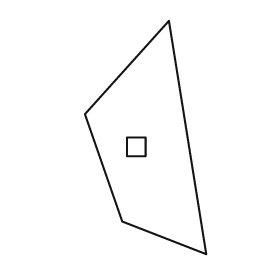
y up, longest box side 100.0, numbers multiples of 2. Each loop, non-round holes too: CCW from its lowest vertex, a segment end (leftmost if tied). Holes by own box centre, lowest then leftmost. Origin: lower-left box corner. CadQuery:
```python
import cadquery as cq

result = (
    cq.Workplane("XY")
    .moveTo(52.0, 0.0)
    .lineTo(36.0, 100.0)
    .lineTo(0.0, 60.0)
    .lineTo(16.0, 14.0)
    .close()
    .moveTo(18.0, 42.0)
    .lineTo(26.0, 42.0)
    .lineTo(26.0, 50.0)
    .lineTo(18.0, 50.0)
    .close()
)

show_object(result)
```